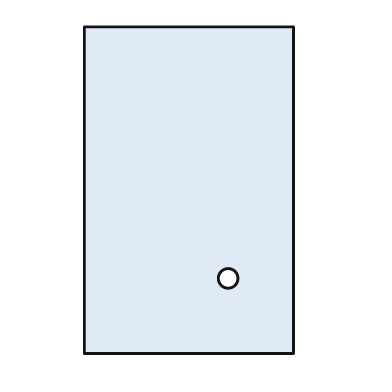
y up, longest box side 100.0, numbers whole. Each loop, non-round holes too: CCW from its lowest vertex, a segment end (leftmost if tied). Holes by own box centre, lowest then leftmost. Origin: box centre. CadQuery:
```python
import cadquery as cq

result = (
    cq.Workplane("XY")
    .moveTo(-32.0, -50.0)
    .lineTo(32.0, -50.0)
    .lineTo(32.0, 50.0)
    .lineTo(-32.0, 50.0)
    .close()
    .moveTo(12.0, -27.0)
    .circle(3.0)
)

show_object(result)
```